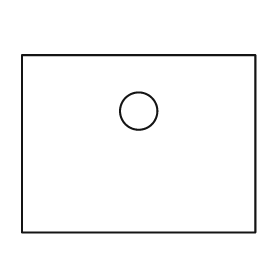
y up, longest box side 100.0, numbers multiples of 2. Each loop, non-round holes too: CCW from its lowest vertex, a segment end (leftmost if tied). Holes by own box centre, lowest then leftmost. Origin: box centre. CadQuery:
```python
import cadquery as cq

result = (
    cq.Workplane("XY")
    .moveTo(-50.0, -38.0)
    .lineTo(50.0, -38.0)
    .lineTo(50.0, 38.0)
    .lineTo(-50.0, 38.0)
    .close()
    .moveTo(0.0, 14.0)
    .circle(8.0)
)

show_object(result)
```